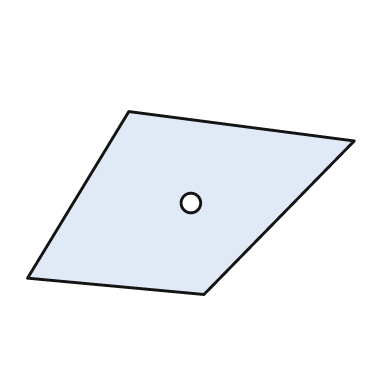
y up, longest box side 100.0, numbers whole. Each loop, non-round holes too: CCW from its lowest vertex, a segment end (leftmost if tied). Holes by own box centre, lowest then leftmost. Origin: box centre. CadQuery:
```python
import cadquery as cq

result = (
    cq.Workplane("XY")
    .moveTo(4.0, -28.0)
    .lineTo(50.0, 19.0)
    .lineTo(-19.0, 28.0)
    .lineTo(-50.0, -23.0)
    .close()
    .moveTo(0.0, 0.0)
    .circle(3.0)
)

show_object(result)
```